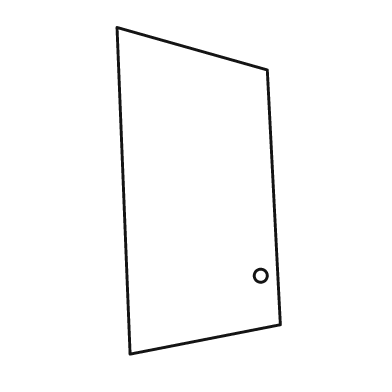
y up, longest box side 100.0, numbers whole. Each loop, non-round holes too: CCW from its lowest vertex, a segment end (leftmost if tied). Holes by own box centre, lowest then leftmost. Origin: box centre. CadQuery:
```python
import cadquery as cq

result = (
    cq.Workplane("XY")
    .moveTo(-21.0, -50.0)
    .lineTo(25.0, -41.0)
    .lineTo(21.0, 37.0)
    .lineTo(-25.0, 50.0)
    .close()
    .moveTo(19.0, -26.0)
    .circle(2.0)
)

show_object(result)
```